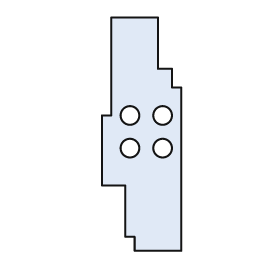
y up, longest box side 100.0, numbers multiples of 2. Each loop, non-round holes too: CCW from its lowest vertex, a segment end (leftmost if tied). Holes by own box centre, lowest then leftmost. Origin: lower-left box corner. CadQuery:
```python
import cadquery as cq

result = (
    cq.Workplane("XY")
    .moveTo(14.0, 0.0)
    .lineTo(34.0, 0.0)
    .lineTo(34.0, 70.0)
    .lineTo(30.0, 70.0)
    .lineTo(30.0, 78.0)
    .lineTo(24.0, 78.0)
    .lineTo(24.0, 100.0)
    .lineTo(4.0, 100.0)
    .lineTo(4.0, 58.0)
    .lineTo(0.0, 58.0)
    .lineTo(0.0, 28.0)
    .lineTo(10.0, 28.0)
    .lineTo(10.0, 6.0)
    .lineTo(14.0, 6.0)
    .close()
    .moveTo(12.0, 44.0)
    .circle(4.0)
    .moveTo(26.0, 44.0)
    .circle(4.0)
    .moveTo(12.0, 58.0)
    .circle(4.0)
    .moveTo(26.0, 58.0)
    .circle(4.0)
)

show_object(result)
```